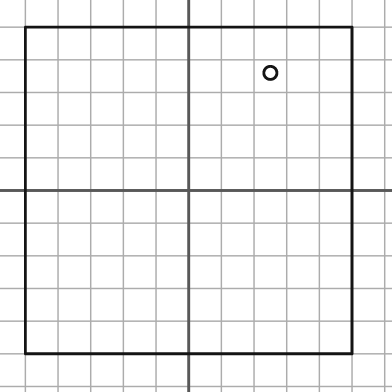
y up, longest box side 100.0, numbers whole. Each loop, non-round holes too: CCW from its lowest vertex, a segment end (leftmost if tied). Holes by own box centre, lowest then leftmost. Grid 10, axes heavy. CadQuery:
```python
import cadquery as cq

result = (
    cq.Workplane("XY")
    .moveTo(-50.0, -50.0)
    .lineTo(50.0, -50.0)
    .lineTo(50.0, 50.0)
    .lineTo(-50.0, 50.0)
    .close()
    .moveTo(25.0, 36.0)
    .circle(2.0)
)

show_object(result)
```